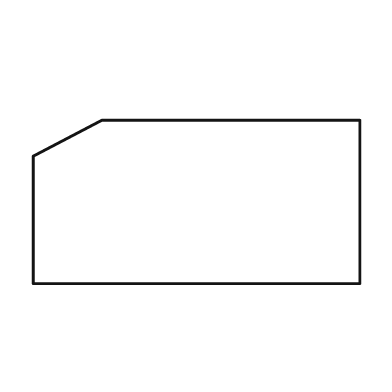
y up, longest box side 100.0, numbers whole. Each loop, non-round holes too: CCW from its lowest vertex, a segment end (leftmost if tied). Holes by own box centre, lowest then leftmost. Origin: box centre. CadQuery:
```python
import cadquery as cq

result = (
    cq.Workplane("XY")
    .moveTo(-50.0, -25.0)
    .lineTo(50.0, -25.0)
    .lineTo(50.0, 25.0)
    .lineTo(-29.0, 25.0)
    .lineTo(-50.0, 14.0)
    .close()
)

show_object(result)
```